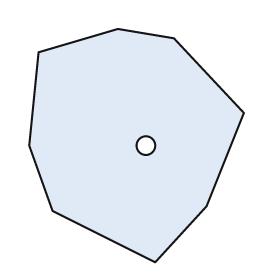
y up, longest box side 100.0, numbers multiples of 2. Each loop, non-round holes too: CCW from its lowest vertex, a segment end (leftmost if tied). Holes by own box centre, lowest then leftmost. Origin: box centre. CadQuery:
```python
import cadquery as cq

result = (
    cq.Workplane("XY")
    .moveTo(8.0, -50.0)
    .lineTo(30.0, -26.0)
    .lineTo(46.0, 14.0)
    .lineTo(16.0, 46.0)
    .lineTo(-8.0, 50.0)
    .lineTo(-42.0, 40.0)
    .lineTo(-46.0, 0.0)
    .lineTo(-36.0, -28.0)
    .close()
    .moveTo(4.0, 0.0)
    .circle(4.0)
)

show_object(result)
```